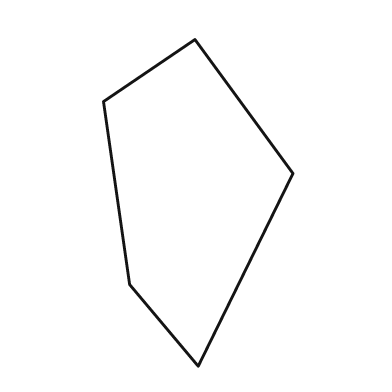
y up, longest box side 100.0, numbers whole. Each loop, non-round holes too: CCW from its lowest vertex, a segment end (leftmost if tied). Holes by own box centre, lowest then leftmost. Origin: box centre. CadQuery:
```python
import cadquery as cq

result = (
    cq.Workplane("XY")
    .moveTo(0.0, -50.0)
    .lineTo(29.0, 9.0)
    .lineTo(-1.0, 50.0)
    .lineTo(-29.0, 31.0)
    .lineTo(-21.0, -25.0)
    .close()
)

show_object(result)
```